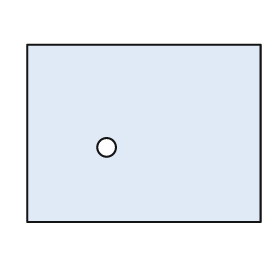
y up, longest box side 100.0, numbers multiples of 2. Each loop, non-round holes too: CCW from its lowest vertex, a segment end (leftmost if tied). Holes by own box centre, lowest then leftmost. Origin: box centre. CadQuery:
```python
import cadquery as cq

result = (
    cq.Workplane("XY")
    .moveTo(-50.0, -38.0)
    .lineTo(50.0, -38.0)
    .lineTo(50.0, 38.0)
    .lineTo(-50.0, 38.0)
    .close()
    .moveTo(-16.0, -6.0)
    .circle(4.0)
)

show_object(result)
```